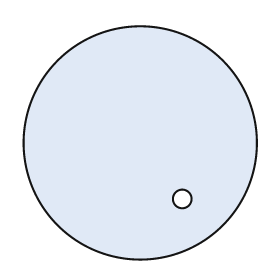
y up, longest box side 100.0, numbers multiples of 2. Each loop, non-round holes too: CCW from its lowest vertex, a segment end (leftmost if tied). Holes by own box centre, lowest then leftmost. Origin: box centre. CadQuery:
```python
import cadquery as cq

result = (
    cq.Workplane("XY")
    .moveTo(0.0, 0.0)
    .circle(50.0)
    .moveTo(18.0, -24.0)
    .circle(4.0)
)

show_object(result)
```